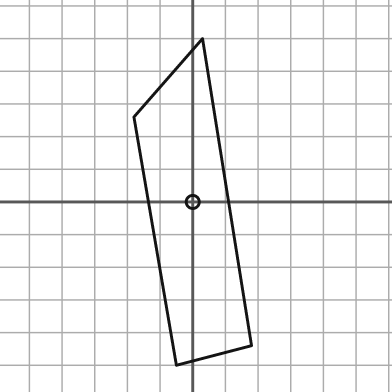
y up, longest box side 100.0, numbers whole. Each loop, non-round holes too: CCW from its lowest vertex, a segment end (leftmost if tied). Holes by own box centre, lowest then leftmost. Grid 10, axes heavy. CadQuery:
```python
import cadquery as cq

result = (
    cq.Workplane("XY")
    .moveTo(-5.0, -50.0)
    .lineTo(18.0, -44.0)
    .lineTo(3.0, 50.0)
    .lineTo(-18.0, 26.0)
    .close()
    .moveTo(0.0, 0.0)
    .circle(2.0)
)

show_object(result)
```